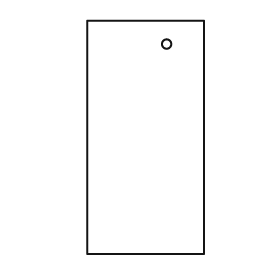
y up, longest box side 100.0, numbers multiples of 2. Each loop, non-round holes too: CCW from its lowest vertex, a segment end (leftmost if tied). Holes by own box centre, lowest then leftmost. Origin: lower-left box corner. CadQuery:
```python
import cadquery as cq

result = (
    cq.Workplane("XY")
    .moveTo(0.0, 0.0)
    .lineTo(50.0, 0.0)
    .lineTo(50.0, 100.0)
    .lineTo(0.0, 100.0)
    .close()
    .moveTo(34.0, 90.0)
    .circle(2.0)
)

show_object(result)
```